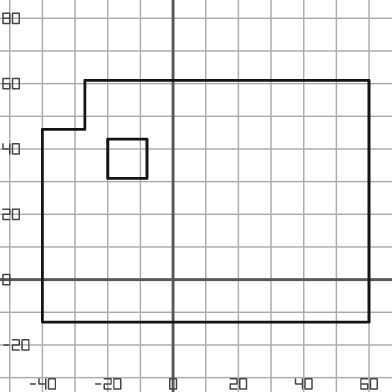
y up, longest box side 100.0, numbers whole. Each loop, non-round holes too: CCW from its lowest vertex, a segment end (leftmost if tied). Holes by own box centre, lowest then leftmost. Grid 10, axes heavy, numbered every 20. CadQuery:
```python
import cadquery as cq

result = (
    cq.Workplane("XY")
    .moveTo(-40.0, -13.0)
    .lineTo(60.0, -13.0)
    .lineTo(60.0, 61.0)
    .lineTo(-27.0, 61.0)
    .lineTo(-27.0, 46.0)
    .lineTo(-40.0, 46.0)
    .close()
    .moveTo(-20.0, 31.0)
    .lineTo(-8.0, 31.0)
    .lineTo(-8.0, 43.0)
    .lineTo(-20.0, 43.0)
    .close()
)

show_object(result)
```